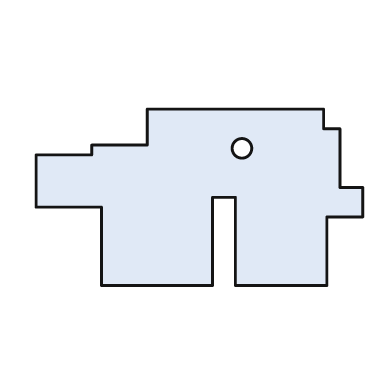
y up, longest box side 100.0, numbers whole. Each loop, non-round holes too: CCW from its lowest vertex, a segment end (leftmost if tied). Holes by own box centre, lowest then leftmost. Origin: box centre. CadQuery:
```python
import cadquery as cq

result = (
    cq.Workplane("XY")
    .moveTo(-30.0, -27.0)
    .lineTo(4.0, -27.0)
    .lineTo(4.0, 0.0)
    .lineTo(11.0, 0.0)
    .lineTo(11.0, -27.0)
    .lineTo(39.0, -27.0)
    .lineTo(39.0, -6.0)
    .lineTo(50.0, -6.0)
    .lineTo(50.0, 3.0)
    .lineTo(43.0, 3.0)
    .lineTo(43.0, 21.0)
    .lineTo(38.0, 21.0)
    .lineTo(38.0, 27.0)
    .lineTo(-16.0, 27.0)
    .lineTo(-16.0, 16.0)
    .lineTo(-33.0, 16.0)
    .lineTo(-33.0, 13.0)
    .lineTo(-50.0, 13.0)
    .lineTo(-50.0, -3.0)
    .lineTo(-30.0, -3.0)
    .close()
    .moveTo(13.0, 15.0)
    .circle(3.0)
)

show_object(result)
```